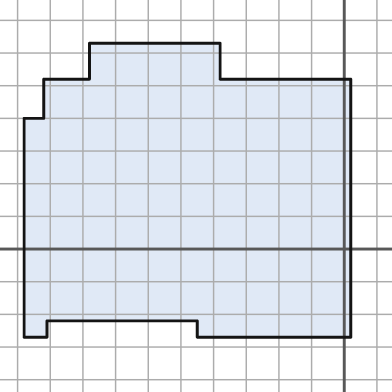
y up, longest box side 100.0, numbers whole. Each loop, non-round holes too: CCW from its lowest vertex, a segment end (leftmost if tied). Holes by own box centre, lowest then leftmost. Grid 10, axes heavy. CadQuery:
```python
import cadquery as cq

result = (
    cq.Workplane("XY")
    .moveTo(-98.0, -27.0)
    .lineTo(-91.0, -27.0)
    .lineTo(-91.0, -22.0)
    .lineTo(-45.0, -22.0)
    .lineTo(-45.0, -27.0)
    .lineTo(2.0, -27.0)
    .lineTo(2.0, 52.0)
    .lineTo(-38.0, 52.0)
    .lineTo(-38.0, 63.0)
    .lineTo(-78.0, 63.0)
    .lineTo(-78.0, 52.0)
    .lineTo(-92.0, 52.0)
    .lineTo(-92.0, 40.0)
    .lineTo(-98.0, 40.0)
    .close()
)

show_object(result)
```